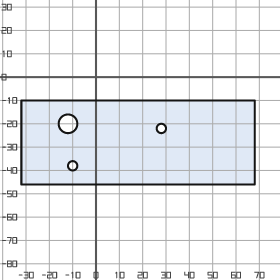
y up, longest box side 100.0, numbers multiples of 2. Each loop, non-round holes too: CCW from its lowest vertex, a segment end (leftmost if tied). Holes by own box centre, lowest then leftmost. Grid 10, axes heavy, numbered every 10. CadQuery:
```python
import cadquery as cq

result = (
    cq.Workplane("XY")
    .moveTo(-32.0, -46.0)
    .lineTo(68.0, -46.0)
    .lineTo(68.0, -10.0)
    .lineTo(-32.0, -10.0)
    .close()
    .moveTo(-10.0, -38.0)
    .circle(2.0)
    .moveTo(28.0, -22.0)
    .circle(2.0)
    .moveTo(-12.0, -20.0)
    .circle(4.0)
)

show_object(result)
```